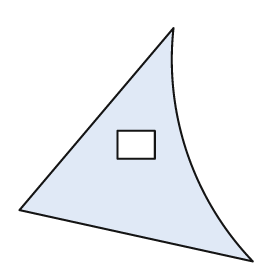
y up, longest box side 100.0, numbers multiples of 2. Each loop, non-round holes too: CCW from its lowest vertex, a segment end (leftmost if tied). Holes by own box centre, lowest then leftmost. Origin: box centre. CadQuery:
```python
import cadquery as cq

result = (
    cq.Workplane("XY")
    .moveTo(50.0, -50.0)
    .threePointArc((22.0, -4.0), (16.0, 50.0))
    .lineTo(-50.0, -28.0)
    .close()
    .moveTo(-8.0, -6.0)
    .lineTo(8.0, -6.0)
    .lineTo(8.0, 6.0)
    .lineTo(-8.0, 6.0)
    .close()
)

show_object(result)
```